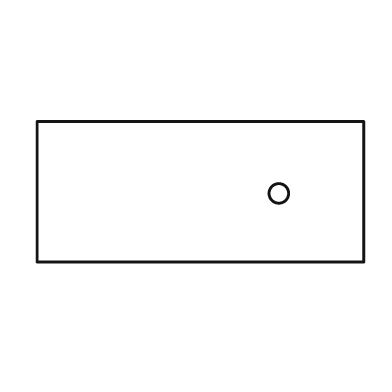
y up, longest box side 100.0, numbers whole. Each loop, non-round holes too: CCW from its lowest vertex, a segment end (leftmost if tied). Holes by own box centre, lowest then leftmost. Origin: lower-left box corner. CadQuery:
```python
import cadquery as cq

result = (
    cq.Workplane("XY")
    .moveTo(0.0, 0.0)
    .lineTo(100.0, 0.0)
    .lineTo(100.0, 43.0)
    .lineTo(0.0, 43.0)
    .close()
    .moveTo(74.0, 21.0)
    .circle(3.0)
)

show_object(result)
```